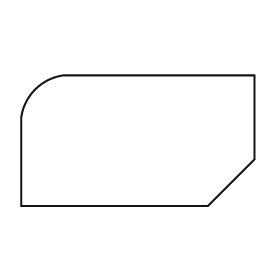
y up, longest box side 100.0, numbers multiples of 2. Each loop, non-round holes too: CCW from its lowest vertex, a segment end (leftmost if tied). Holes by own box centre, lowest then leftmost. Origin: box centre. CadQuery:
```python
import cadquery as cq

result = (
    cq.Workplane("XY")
    .moveTo(-50.0, -28.0)
    .lineTo(30.0, -28.0)
    .lineTo(50.0, -8.0)
    .lineTo(50.0, 28.0)
    .lineTo(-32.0, 28.0)
    .threePointArc((-44.0, 22.0), (-50.0, 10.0))
    .close()
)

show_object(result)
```